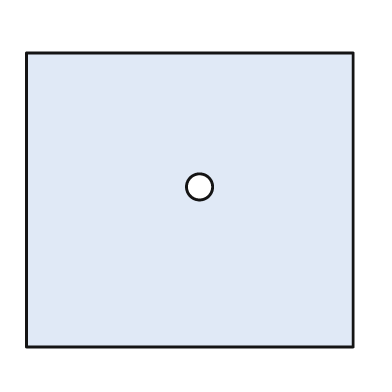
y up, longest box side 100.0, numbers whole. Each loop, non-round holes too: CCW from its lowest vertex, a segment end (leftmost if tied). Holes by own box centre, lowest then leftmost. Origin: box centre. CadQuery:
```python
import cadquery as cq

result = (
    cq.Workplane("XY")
    .moveTo(-50.0, -45.0)
    .lineTo(50.0, -45.0)
    .lineTo(50.0, 45.0)
    .lineTo(-50.0, 45.0)
    .close()
    .moveTo(3.0, 4.0)
    .circle(4.0)
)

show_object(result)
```